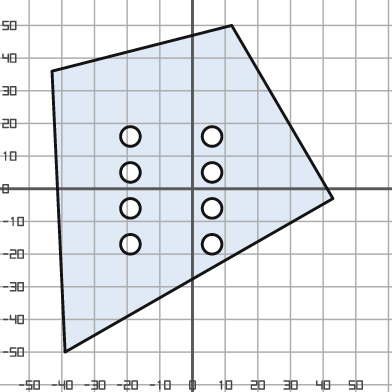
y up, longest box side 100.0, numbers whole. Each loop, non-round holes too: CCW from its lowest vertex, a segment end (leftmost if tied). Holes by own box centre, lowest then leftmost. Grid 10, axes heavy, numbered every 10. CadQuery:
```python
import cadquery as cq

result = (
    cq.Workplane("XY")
    .moveTo(-39.0, -50.0)
    .lineTo(43.0, -3.0)
    .lineTo(12.0, 50.0)
    .lineTo(-43.0, 36.0)
    .close()
    .moveTo(-19.0, -17.0)
    .circle(3.0)
    .moveTo(6.0, -17.0)
    .circle(3.0)
    .moveTo(-19.0, -6.0)
    .circle(3.0)
    .moveTo(6.0, -6.0)
    .circle(3.0)
    .moveTo(-19.0, 5.0)
    .circle(3.0)
    .moveTo(6.0, 5.0)
    .circle(3.0)
    .moveTo(-19.0, 16.0)
    .circle(3.0)
    .moveTo(6.0, 16.0)
    .circle(3.0)
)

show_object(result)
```